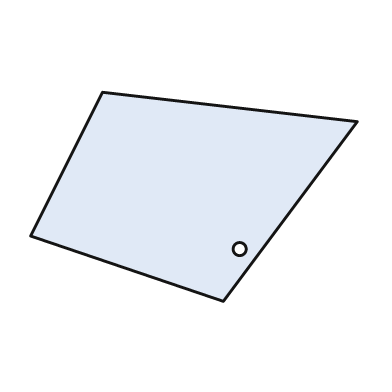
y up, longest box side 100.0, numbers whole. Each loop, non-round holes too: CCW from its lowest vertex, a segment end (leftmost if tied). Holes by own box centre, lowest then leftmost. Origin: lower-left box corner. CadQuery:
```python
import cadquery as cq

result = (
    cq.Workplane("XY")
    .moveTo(59.0, 0.0)
    .lineTo(100.0, 55.0)
    .lineTo(22.0, 64.0)
    .lineTo(0.0, 20.0)
    .close()
    .moveTo(64.0, 16.0)
    .circle(2.0)
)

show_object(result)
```